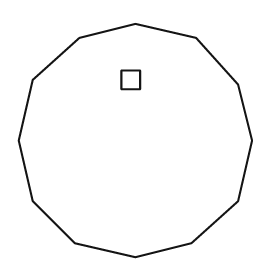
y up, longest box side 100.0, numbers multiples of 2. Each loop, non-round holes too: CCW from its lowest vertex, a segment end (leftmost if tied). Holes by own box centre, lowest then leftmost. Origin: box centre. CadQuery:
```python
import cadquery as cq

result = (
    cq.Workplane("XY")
    .moveTo(0.0, -50.0)
    .lineTo(24.0, -44.0)
    .lineTo(44.0, -26.0)
    .lineTo(50.0, 0.0)
    .lineTo(44.0, 24.0)
    .lineTo(26.0, 44.0)
    .lineTo(0.0, 50.0)
    .lineTo(-24.0, 44.0)
    .lineTo(-44.0, 26.0)
    .lineTo(-50.0, 0.0)
    .lineTo(-44.0, -26.0)
    .lineTo(-26.0, -44.0)
    .close()
    .moveTo(-6.0, 22.0)
    .lineTo(2.0, 22.0)
    .lineTo(2.0, 30.0)
    .lineTo(-6.0, 30.0)
    .close()
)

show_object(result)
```